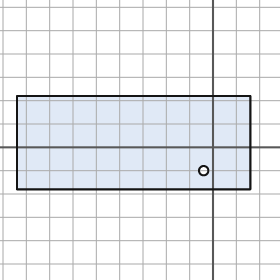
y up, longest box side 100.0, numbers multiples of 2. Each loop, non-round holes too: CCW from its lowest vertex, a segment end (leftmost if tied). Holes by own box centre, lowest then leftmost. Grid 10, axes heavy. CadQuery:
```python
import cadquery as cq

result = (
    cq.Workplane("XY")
    .moveTo(-84.0, -18.0)
    .lineTo(16.0, -18.0)
    .lineTo(16.0, 22.0)
    .lineTo(-84.0, 22.0)
    .close()
    .moveTo(-4.0, -10.0)
    .circle(2.0)
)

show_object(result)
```